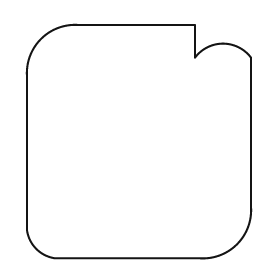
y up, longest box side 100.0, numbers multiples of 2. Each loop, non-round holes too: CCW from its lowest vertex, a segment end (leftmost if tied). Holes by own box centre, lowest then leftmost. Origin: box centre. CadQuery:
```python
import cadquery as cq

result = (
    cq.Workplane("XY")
    .moveTo(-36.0, -50.0)
    .lineTo(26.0, -50.0)
    .threePointArc((42.0, -44.0), (48.0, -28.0))
    .lineTo(48.0, 36.0)
    .threePointArc((36.0, 42.0), (24.0, 36.0))
    .lineTo(24.0, 50.0)
    .lineTo(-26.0, 50.0)
    .threePointArc((-42.0, 44.0), (-48.0, 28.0))
    .lineTo(-48.0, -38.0)
    .threePointArc((-44.0, -46.0), (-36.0, -50.0))
    .close()
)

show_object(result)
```